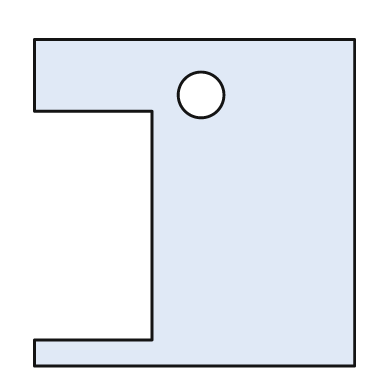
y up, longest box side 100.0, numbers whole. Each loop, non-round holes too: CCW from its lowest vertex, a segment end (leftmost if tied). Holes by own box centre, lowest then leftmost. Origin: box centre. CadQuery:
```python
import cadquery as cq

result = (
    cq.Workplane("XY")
    .moveTo(-49.0, -50.0)
    .lineTo(49.0, -50.0)
    .lineTo(49.0, 50.0)
    .lineTo(-49.0, 50.0)
    .lineTo(-49.0, 28.0)
    .lineTo(-13.0, 28.0)
    .lineTo(-13.0, -42.0)
    .lineTo(-49.0, -42.0)
    .close()
    .moveTo(2.0, 33.0)
    .circle(7.0)
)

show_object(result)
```